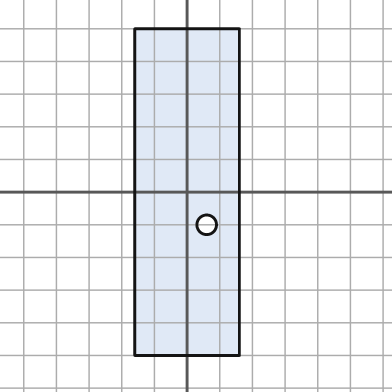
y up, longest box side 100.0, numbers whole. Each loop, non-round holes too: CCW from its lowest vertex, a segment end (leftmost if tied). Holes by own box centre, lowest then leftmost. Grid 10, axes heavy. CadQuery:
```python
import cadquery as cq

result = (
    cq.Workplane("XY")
    .moveTo(-16.0, -50.0)
    .lineTo(16.0, -50.0)
    .lineTo(16.0, 50.0)
    .lineTo(-16.0, 50.0)
    .close()
    .moveTo(6.0, -10.0)
    .circle(3.0)
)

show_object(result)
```